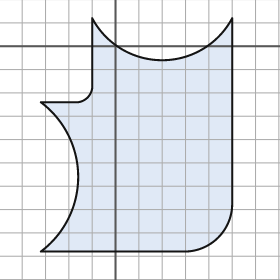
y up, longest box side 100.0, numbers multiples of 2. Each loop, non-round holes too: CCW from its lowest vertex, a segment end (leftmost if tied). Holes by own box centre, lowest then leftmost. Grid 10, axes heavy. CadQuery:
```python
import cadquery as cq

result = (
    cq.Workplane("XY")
    .moveTo(-32.0, -88.0)
    .lineTo(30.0, -88.0)
    .threePointArc((44.0, -82.0), (50.0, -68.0))
    .lineTo(50.0, 12.0)
    .threePointArc((20.0, -6.0), (-10.0, 12.0))
    .lineTo(-10.0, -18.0)
    .threePointArc((-12.0, -22.0), (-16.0, -24.0))
    .lineTo(-32.0, -24.0)
    .threePointArc((-16.0, -56.0), (-32.0, -88.0))
    .close()
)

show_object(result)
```